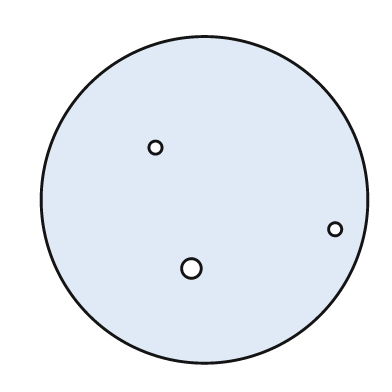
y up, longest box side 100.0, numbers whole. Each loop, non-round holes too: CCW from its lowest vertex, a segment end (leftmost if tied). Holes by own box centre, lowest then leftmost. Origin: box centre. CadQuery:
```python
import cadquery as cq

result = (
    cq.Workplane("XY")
    .moveTo(0.0, 0.0)
    .circle(50.0)
    .moveTo(-4.0, -21.0)
    .circle(3.0)
    .moveTo(40.0, -9.0)
    .circle(2.0)
    .moveTo(-15.0, 16.0)
    .circle(2.0)
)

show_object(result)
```